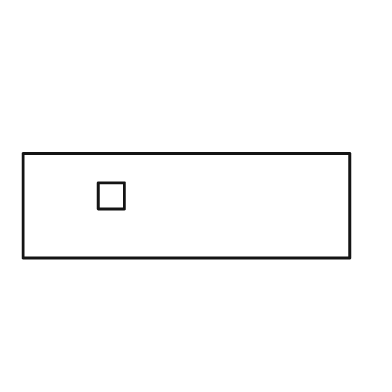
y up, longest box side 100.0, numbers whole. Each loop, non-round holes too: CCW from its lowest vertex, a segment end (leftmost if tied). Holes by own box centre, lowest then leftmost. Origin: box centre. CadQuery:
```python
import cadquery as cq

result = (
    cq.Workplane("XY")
    .moveTo(-50.0, -16.0)
    .lineTo(50.0, -16.0)
    .lineTo(50.0, 16.0)
    .lineTo(-50.0, 16.0)
    .close()
    .moveTo(-27.0, -1.0)
    .lineTo(-19.0, -1.0)
    .lineTo(-19.0, 7.0)
    .lineTo(-27.0, 7.0)
    .close()
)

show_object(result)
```